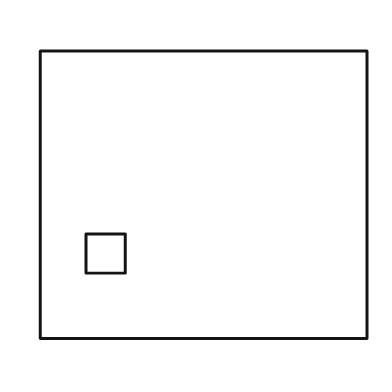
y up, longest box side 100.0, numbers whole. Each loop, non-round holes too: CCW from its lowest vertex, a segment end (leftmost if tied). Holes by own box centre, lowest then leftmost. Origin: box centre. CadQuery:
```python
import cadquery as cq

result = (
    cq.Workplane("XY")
    .moveTo(-50.0, -44.0)
    .lineTo(50.0, -44.0)
    .lineTo(50.0, 44.0)
    .lineTo(-50.0, 44.0)
    .close()
    .moveTo(-36.0, -24.0)
    .lineTo(-24.0, -24.0)
    .lineTo(-24.0, -12.0)
    .lineTo(-36.0, -12.0)
    .close()
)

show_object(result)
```